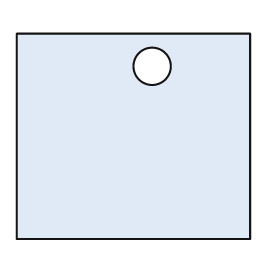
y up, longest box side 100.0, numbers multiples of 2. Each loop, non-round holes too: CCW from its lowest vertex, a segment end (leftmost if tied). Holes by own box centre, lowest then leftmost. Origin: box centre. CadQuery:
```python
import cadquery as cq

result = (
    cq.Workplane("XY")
    .moveTo(-50.0, -44.0)
    .lineTo(50.0, -44.0)
    .lineTo(50.0, 44.0)
    .lineTo(-50.0, 44.0)
    .close()
    .moveTo(8.0, 30.0)
    .circle(8.0)
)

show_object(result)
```